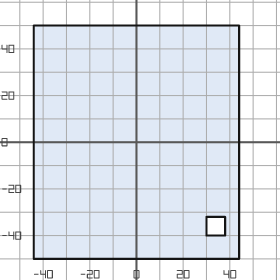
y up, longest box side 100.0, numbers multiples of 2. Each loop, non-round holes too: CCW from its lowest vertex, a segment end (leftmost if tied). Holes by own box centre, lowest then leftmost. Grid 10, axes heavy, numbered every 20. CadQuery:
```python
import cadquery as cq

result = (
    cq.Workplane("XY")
    .moveTo(-44.0, -50.0)
    .lineTo(44.0, -50.0)
    .lineTo(44.0, 50.0)
    .lineTo(-44.0, 50.0)
    .close()
    .moveTo(30.0, -40.0)
    .lineTo(38.0, -40.0)
    .lineTo(38.0, -32.0)
    .lineTo(30.0, -32.0)
    .close()
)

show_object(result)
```